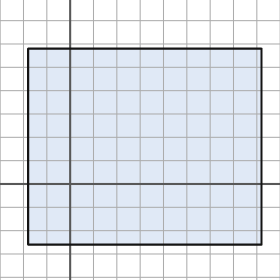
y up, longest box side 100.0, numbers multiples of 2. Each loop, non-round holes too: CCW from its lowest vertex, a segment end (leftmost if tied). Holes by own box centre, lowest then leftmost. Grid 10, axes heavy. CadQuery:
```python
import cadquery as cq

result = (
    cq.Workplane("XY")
    .moveTo(-18.0, -26.0)
    .lineTo(82.0, -26.0)
    .lineTo(82.0, 58.0)
    .lineTo(-18.0, 58.0)
    .close()
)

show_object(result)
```